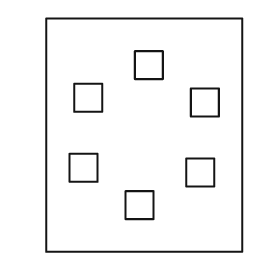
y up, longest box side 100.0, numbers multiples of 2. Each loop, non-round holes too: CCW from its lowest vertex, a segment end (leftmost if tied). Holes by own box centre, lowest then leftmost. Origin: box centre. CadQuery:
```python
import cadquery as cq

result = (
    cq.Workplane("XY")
    .moveTo(-42.0, -50.0)
    .lineTo(42.0, -50.0)
    .lineTo(42.0, 50.0)
    .lineTo(-42.0, 50.0)
    .close()
    .moveTo(-8.0, -36.0)
    .lineTo(4.0, -36.0)
    .lineTo(4.0, -24.0)
    .lineTo(-8.0, -24.0)
    .close()
    .moveTo(18.0, -22.0)
    .lineTo(30.0, -22.0)
    .lineTo(30.0, -10.0)
    .lineTo(18.0, -10.0)
    .close()
    .moveTo(-32.0, -20.0)
    .lineTo(-20.0, -20.0)
    .lineTo(-20.0, -8.0)
    .lineTo(-32.0, -8.0)
    .close()
    .moveTo(20.0, 8.0)
    .lineTo(32.0, 8.0)
    .lineTo(32.0, 20.0)
    .lineTo(20.0, 20.0)
    .close()
    .moveTo(-30.0, 10.0)
    .lineTo(-18.0, 10.0)
    .lineTo(-18.0, 22.0)
    .lineTo(-30.0, 22.0)
    .close()
    .moveTo(-4.0, 24.0)
    .lineTo(8.0, 24.0)
    .lineTo(8.0, 36.0)
    .lineTo(-4.0, 36.0)
    .close()
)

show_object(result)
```